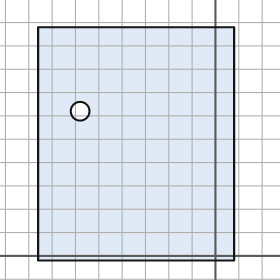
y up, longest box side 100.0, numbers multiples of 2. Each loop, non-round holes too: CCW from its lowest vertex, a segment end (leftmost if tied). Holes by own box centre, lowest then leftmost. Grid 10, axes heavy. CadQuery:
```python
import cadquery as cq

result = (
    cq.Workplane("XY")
    .moveTo(-76.0, -2.0)
    .lineTo(8.0, -2.0)
    .lineTo(8.0, 98.0)
    .lineTo(-76.0, 98.0)
    .close()
    .moveTo(-58.0, 62.0)
    .circle(4.0)
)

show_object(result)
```